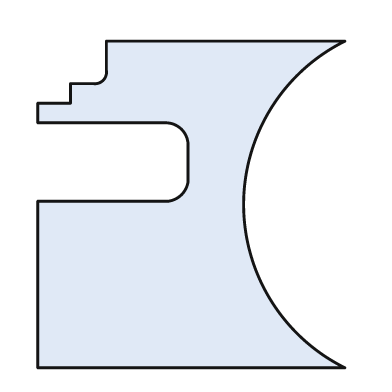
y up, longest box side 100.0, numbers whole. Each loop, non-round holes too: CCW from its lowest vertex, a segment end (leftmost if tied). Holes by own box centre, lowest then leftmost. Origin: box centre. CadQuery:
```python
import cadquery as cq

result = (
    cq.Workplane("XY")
    .moveTo(-47.0, -50.0)
    .lineTo(47.0, -50.0)
    .threePointArc((16.0, 0.0), (47.0, 50.0))
    .lineTo(-26.0, 50.0)
    .lineTo(-26.0, 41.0)
    .threePointArc((-27.0, 38.0), (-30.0, 37.0))
    .lineTo(-37.0, 37.0)
    .lineTo(-37.0, 31.0)
    .lineTo(-47.0, 31.0)
    .lineTo(-47.0, 25.0)
    .lineTo(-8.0, 25.0)
    .threePointArc((-3.0, 23.0), (-1.0, 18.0))
    .lineTo(-1.0, 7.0)
    .threePointArc((-3.0, 3.0), (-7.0, 1.0))
    .lineTo(-47.0, 1.0)
    .close()
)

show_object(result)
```